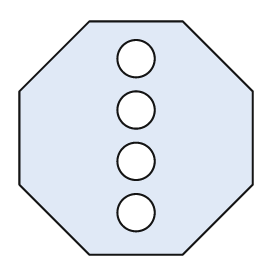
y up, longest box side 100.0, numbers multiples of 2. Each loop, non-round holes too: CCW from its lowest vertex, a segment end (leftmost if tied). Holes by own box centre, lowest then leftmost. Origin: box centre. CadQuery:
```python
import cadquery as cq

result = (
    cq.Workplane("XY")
    .moveTo(-20.0, -50.0)
    .lineTo(20.0, -50.0)
    .lineTo(50.0, -20.0)
    .lineTo(50.0, 20.0)
    .lineTo(20.0, 50.0)
    .lineTo(-20.0, 50.0)
    .lineTo(-50.0, 20.0)
    .lineTo(-50.0, -20.0)
    .close()
    .moveTo(0.0, -32.0)
    .circle(8.0)
    .moveTo(0.0, -10.0)
    .circle(8.0)
    .moveTo(0.0, 12.0)
    .circle(8.0)
    .moveTo(0.0, 34.0)
    .circle(8.0)
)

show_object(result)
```